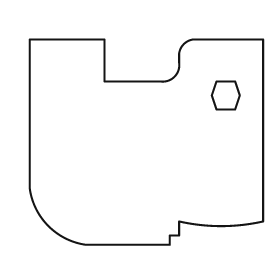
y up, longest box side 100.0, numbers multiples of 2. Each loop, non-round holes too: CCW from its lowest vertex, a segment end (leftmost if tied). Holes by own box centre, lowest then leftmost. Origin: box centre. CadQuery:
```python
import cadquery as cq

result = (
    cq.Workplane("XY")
    .moveTo(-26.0, -44.0)
    .lineTo(10.0, -44.0)
    .lineTo(10.0, -40.0)
    .lineTo(14.0, -40.0)
    .lineTo(14.0, -34.0)
    .threePointArc((32.0, -36.0), (50.0, -34.0))
    .lineTo(50.0, 44.0)
    .lineTo(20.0, 44.0)
    .threePointArc((16.0, 42.0), (14.0, 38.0))
    .lineTo(14.0, 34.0)
    .threePointArc((12.0, 28.0), (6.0, 26.0))
    .lineTo(-18.0, 26.0)
    .lineTo(-18.0, 44.0)
    .lineTo(-50.0, 44.0)
    .lineTo(-50.0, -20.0)
    .threePointArc((-42.0, -36.0), (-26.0, -44.0))
    .close()
    .moveTo(30.0, 14.0)
    .lineTo(38.0, 14.0)
    .lineTo(40.0, 20.0)
    .lineTo(38.0, 26.0)
    .lineTo(30.0, 26.0)
    .lineTo(28.0, 20.0)
    .close()
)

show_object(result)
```